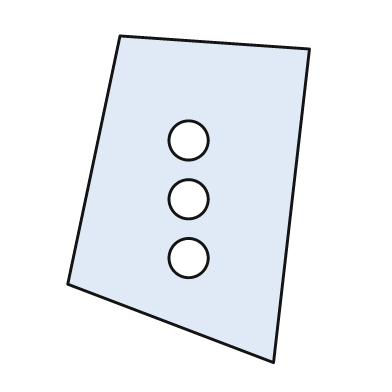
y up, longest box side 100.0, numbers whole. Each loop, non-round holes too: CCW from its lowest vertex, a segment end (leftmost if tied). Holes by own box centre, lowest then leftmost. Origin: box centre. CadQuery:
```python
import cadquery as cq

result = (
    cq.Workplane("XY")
    .moveTo(26.0, -50.0)
    .lineTo(37.0, 46.0)
    .lineTo(-21.0, 50.0)
    .lineTo(-37.0, -26.0)
    .close()
    .moveTo(0.0, -18.0)
    .circle(6.0)
    .moveTo(0.0, 0.0)
    .circle(6.0)
    .moveTo(0.0, 18.0)
    .circle(6.0)
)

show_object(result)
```